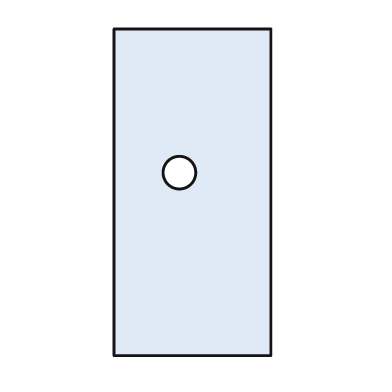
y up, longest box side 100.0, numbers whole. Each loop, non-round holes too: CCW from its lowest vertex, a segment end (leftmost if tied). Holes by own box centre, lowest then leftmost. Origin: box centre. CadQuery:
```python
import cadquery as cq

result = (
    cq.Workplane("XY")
    .moveTo(-24.0, -50.0)
    .lineTo(24.0, -50.0)
    .lineTo(24.0, 50.0)
    .lineTo(-24.0, 50.0)
    .close()
    .moveTo(-4.0, 6.0)
    .circle(5.0)
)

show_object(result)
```